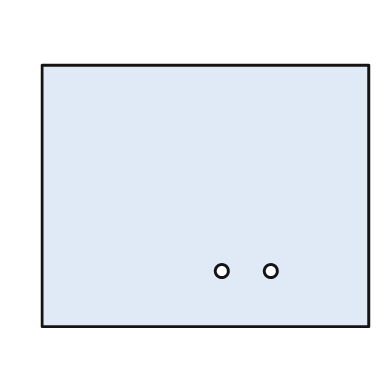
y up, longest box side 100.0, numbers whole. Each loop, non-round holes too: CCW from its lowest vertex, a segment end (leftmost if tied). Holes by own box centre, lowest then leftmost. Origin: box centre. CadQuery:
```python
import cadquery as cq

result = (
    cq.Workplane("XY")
    .moveTo(-50.0, -40.0)
    .lineTo(50.0, -40.0)
    .lineTo(50.0, 40.0)
    .lineTo(-50.0, 40.0)
    .close()
    .moveTo(5.0, -23.0)
    .circle(2.0)
    .moveTo(20.0, -23.0)
    .circle(2.0)
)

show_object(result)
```